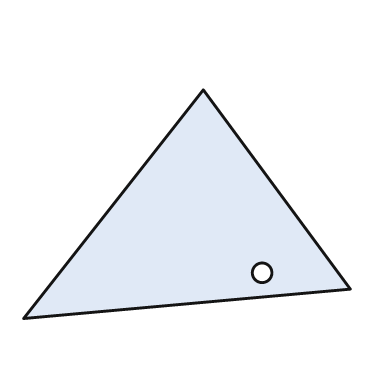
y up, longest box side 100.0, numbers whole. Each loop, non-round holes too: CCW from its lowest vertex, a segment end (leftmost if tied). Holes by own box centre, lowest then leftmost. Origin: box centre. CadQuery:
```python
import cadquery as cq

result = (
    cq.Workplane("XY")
    .moveTo(-50.0, -35.0)
    .lineTo(50.0, -26.0)
    .lineTo(5.0, 35.0)
    .close()
    .moveTo(23.0, -21.0)
    .circle(3.0)
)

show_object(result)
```